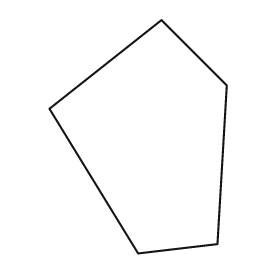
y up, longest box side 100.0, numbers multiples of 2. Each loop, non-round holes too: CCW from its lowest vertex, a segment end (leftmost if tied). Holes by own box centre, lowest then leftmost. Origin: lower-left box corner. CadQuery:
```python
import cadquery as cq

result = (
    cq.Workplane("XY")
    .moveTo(38.0, 0.0)
    .lineTo(72.0, 4.0)
    .lineTo(76.0, 72.0)
    .lineTo(48.0, 100.0)
    .lineTo(0.0, 62.0)
    .close()
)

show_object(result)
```